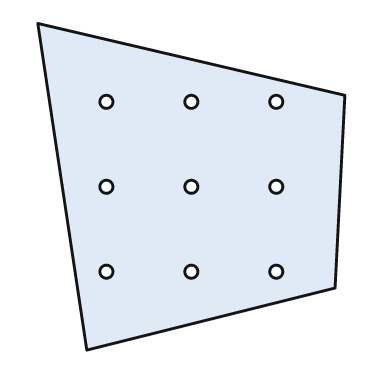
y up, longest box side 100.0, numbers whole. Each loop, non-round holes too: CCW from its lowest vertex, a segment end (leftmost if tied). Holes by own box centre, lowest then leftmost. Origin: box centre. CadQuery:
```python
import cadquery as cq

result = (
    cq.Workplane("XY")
    .moveTo(-32.0, -50.0)
    .lineTo(44.0, -31.0)
    .lineTo(47.0, 28.0)
    .lineTo(-47.0, 50.0)
    .close()
    .moveTo(-26.0, -26.0)
    .circle(2.0)
    .moveTo(0.0, -26.0)
    .circle(2.0)
    .moveTo(26.0, -26.0)
    .circle(2.0)
    .moveTo(-26.0, 0.0)
    .circle(2.0)
    .moveTo(0.0, 0.0)
    .circle(2.0)
    .moveTo(26.0, 0.0)
    .circle(2.0)
    .moveTo(-26.0, 26.0)
    .circle(2.0)
    .moveTo(0.0, 26.0)
    .circle(2.0)
    .moveTo(26.0, 26.0)
    .circle(2.0)
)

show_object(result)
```